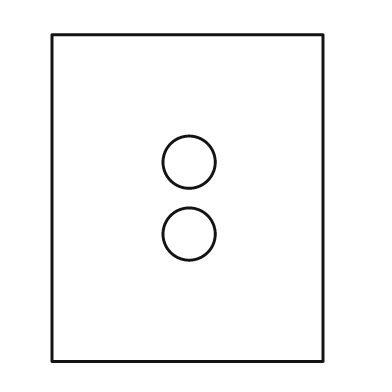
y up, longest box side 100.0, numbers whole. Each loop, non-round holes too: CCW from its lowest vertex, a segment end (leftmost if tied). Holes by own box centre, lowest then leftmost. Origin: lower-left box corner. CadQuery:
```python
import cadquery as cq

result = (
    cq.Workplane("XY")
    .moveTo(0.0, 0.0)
    .lineTo(83.0, 0.0)
    .lineTo(83.0, 100.0)
    .lineTo(0.0, 100.0)
    .close()
    .moveTo(42.0, 39.0)
    .circle(8.0)
    .moveTo(42.0, 61.0)
    .circle(8.0)
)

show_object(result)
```